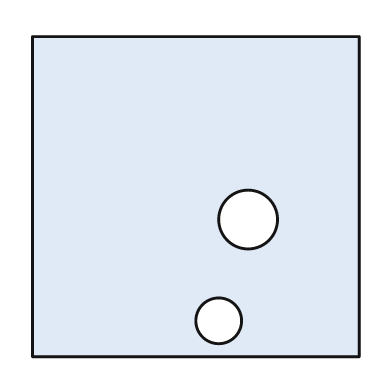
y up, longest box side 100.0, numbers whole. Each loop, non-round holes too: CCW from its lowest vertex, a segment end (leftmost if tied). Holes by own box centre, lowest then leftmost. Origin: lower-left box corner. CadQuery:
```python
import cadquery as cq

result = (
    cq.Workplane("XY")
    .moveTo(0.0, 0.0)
    .lineTo(100.0, 0.0)
    .lineTo(100.0, 98.0)
    .lineTo(0.0, 98.0)
    .close()
    .moveTo(57.0, 11.0)
    .circle(7.0)
    .moveTo(66.0, 42.0)
    .circle(9.0)
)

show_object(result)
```